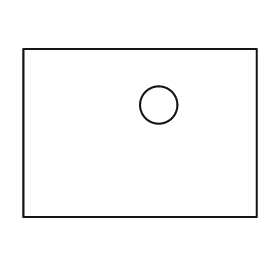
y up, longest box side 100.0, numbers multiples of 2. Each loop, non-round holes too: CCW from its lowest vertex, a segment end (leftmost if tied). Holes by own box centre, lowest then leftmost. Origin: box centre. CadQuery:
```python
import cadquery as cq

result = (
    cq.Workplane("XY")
    .moveTo(-50.0, -36.0)
    .lineTo(50.0, -36.0)
    .lineTo(50.0, 36.0)
    .lineTo(-50.0, 36.0)
    .close()
    .moveTo(8.0, 12.0)
    .circle(8.0)
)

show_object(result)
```